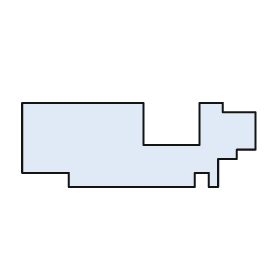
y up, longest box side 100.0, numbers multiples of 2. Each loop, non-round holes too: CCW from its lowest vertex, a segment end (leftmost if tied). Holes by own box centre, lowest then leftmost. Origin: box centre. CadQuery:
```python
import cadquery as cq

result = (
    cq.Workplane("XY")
    .moveTo(-30.0, -18.0)
    .lineTo(24.0, -18.0)
    .lineTo(24.0, -12.0)
    .lineTo(30.0, -12.0)
    .lineTo(30.0, -18.0)
    .lineTo(34.0, -18.0)
    .lineTo(34.0, -6.0)
    .lineTo(42.0, -6.0)
    .lineTo(42.0, -2.0)
    .lineTo(50.0, -2.0)
    .lineTo(50.0, 14.0)
    .lineTo(36.0, 14.0)
    .lineTo(36.0, 18.0)
    .lineTo(26.0, 18.0)
    .lineTo(26.0, 0.0)
    .lineTo(2.0, 0.0)
    .lineTo(2.0, 18.0)
    .lineTo(-50.0, 18.0)
    .lineTo(-50.0, -12.0)
    .lineTo(-30.0, -12.0)
    .close()
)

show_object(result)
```